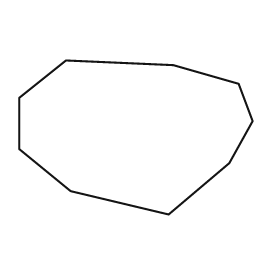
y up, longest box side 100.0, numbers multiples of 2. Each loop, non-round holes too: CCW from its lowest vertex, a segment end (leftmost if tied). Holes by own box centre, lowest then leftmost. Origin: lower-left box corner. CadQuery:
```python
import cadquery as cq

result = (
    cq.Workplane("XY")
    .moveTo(64.0, 0.0)
    .lineTo(90.0, 22.0)
    .lineTo(100.0, 40.0)
    .lineTo(94.0, 56.0)
    .lineTo(66.0, 64.0)
    .lineTo(20.0, 66.0)
    .lineTo(0.0, 50.0)
    .lineTo(0.0, 28.0)
    .lineTo(22.0, 10.0)
    .close()
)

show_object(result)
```